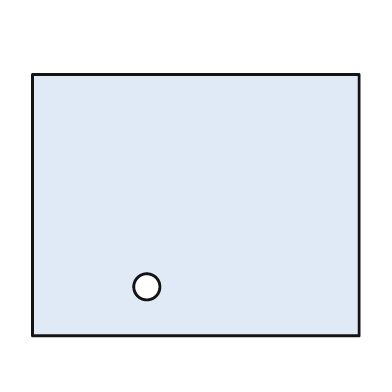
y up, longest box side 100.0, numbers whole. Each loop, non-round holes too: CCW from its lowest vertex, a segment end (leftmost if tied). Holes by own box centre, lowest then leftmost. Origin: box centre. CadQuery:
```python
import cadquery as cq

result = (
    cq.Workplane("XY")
    .moveTo(-50.0, -40.0)
    .lineTo(50.0, -40.0)
    .lineTo(50.0, 40.0)
    .lineTo(-50.0, 40.0)
    .close()
    .moveTo(-15.0, -25.0)
    .circle(4.0)
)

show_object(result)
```